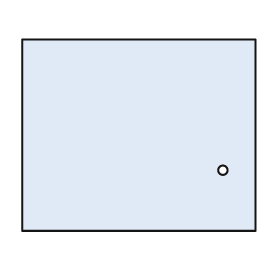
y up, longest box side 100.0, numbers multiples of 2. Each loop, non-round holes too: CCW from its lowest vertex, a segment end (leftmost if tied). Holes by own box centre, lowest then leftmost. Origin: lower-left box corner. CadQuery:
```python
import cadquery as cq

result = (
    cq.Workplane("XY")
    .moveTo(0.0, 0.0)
    .lineTo(100.0, 0.0)
    .lineTo(100.0, 82.0)
    .lineTo(0.0, 82.0)
    .close()
    .moveTo(86.0, 26.0)
    .circle(2.0)
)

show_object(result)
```